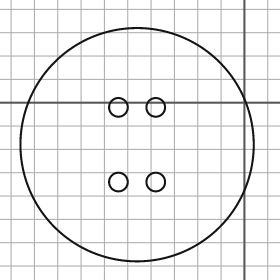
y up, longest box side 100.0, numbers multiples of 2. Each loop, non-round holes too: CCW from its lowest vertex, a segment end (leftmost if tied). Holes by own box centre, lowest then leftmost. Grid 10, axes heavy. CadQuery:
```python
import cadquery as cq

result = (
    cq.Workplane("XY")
    .moveTo(-46.0, -18.0)
    .circle(50.0)
    .moveTo(-54.0, -34.0)
    .circle(4.0)
    .moveTo(-38.0, -34.0)
    .circle(4.0)
    .moveTo(-54.0, -2.0)
    .circle(4.0)
    .moveTo(-38.0, -2.0)
    .circle(4.0)
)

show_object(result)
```